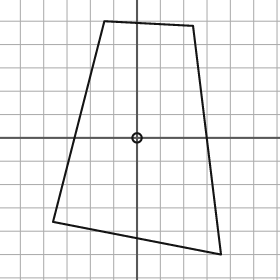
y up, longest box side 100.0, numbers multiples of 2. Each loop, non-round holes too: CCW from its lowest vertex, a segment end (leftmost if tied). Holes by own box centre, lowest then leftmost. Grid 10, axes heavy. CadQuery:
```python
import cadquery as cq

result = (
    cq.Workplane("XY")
    .moveTo(36.0, -50.0)
    .lineTo(24.0, 48.0)
    .lineTo(-14.0, 50.0)
    .lineTo(-36.0, -36.0)
    .close()
    .moveTo(0.0, 0.0)
    .circle(2.0)
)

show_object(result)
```